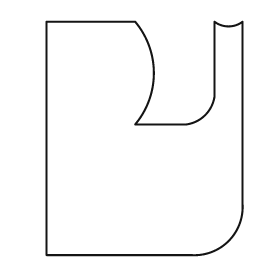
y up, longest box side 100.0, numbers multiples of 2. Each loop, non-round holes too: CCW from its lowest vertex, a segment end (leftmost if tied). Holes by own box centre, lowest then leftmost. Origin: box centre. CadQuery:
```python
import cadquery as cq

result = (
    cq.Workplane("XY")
    .moveTo(-42.0, -50.0)
    .lineTo(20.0, -50.0)
    .threePointArc((36.0, -44.0), (42.0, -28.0))
    .lineTo(42.0, 50.0)
    .threePointArc((36.0, 48.0), (30.0, 50.0))
    .lineTo(30.0, 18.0)
    .threePointArc((26.0, 10.0), (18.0, 6.0))
    .lineTo(-4.0, 6.0)
    .threePointArc((4.0, 28.0), (-4.0, 50.0))
    .lineTo(-42.0, 50.0)
    .close()
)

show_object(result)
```